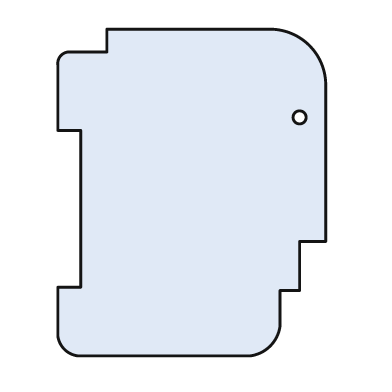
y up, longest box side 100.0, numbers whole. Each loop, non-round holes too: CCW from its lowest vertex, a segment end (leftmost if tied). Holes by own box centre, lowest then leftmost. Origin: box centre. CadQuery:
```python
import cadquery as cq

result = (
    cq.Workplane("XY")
    .moveTo(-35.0, -50.0)
    .lineTo(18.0, -50.0)
    .threePointArc((24.0, -47.0), (27.0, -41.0))
    .lineTo(27.0, -30.0)
    .lineTo(33.0, -30.0)
    .lineTo(33.0, -15.0)
    .lineTo(41.0, -15.0)
    .lineTo(41.0, 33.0)
    .threePointArc((36.0, 45.0), (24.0, 50.0))
    .lineTo(-26.0, 50.0)
    .lineTo(-26.0, 43.0)
    .lineTo(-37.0, 43.0)
    .threePointArc((-40.0, 42.0), (-41.0, 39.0))
    .lineTo(-41.0, 19.0)
    .lineTo(-34.0, 19.0)
    .lineTo(-34.0, -29.0)
    .lineTo(-41.0, -29.0)
    .lineTo(-41.0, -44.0)
    .threePointArc((-39.0, -48.0), (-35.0, -50.0))
    .close()
    .moveTo(33.0, 23.0)
    .circle(2.0)
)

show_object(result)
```